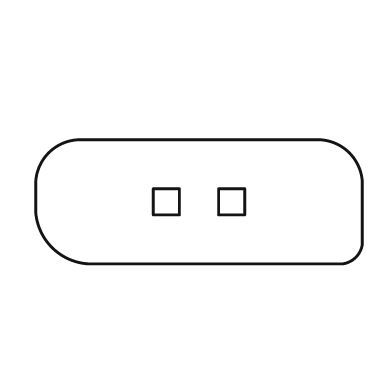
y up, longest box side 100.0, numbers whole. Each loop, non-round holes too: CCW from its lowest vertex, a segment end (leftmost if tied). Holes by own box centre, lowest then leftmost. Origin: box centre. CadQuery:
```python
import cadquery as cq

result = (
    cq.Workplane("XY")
    .moveTo(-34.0, -19.0)
    .lineTo(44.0, -19.0)
    .threePointArc((48.0, -17.0), (50.0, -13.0))
    .lineTo(50.0, 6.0)
    .threePointArc((46.0, 15.0), (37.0, 19.0))
    .lineTo(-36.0, 19.0)
    .threePointArc((-46.0, 15.0), (-50.0, 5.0))
    .lineTo(-50.0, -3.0)
    .threePointArc((-45.0, -14.0), (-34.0, -19.0))
    .close()
    .moveTo(-14.0, -4.0)
    .lineTo(-6.0, -4.0)
    .lineTo(-6.0, 4.0)
    .lineTo(-14.0, 4.0)
    .close()
    .moveTo(6.0, -4.0)
    .lineTo(14.0, -4.0)
    .lineTo(14.0, 4.0)
    .lineTo(6.0, 4.0)
    .close()
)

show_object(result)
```